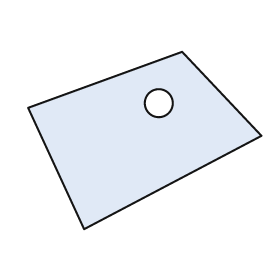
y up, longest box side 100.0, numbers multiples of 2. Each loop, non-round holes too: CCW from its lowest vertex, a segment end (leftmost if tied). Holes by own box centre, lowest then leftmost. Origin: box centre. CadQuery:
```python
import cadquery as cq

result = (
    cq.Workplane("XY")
    .moveTo(-26.0, -38.0)
    .lineTo(50.0, 2.0)
    .lineTo(16.0, 38.0)
    .lineTo(-50.0, 14.0)
    .close()
    .moveTo(6.0, 16.0)
    .circle(6.0)
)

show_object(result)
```